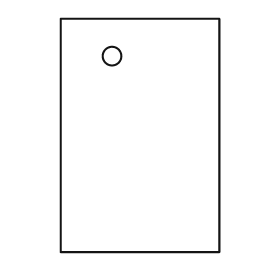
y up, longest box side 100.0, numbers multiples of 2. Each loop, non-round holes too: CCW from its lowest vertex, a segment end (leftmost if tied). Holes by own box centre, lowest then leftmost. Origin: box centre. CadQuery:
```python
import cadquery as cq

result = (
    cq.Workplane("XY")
    .moveTo(-34.0, -50.0)
    .lineTo(34.0, -50.0)
    .lineTo(34.0, 50.0)
    .lineTo(-34.0, 50.0)
    .close()
    .moveTo(-12.0, 34.0)
    .circle(4.0)
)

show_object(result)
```